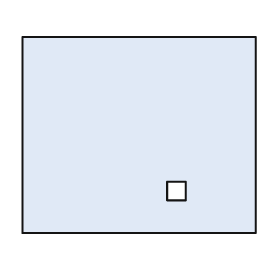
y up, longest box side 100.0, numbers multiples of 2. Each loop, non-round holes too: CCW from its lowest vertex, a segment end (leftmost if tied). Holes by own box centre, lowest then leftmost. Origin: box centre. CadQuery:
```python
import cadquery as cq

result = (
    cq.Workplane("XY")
    .moveTo(-50.0, -42.0)
    .lineTo(50.0, -42.0)
    .lineTo(50.0, 42.0)
    .lineTo(-50.0, 42.0)
    .close()
    .moveTo(12.0, -28.0)
    .lineTo(20.0, -28.0)
    .lineTo(20.0, -20.0)
    .lineTo(12.0, -20.0)
    .close()
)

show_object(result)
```